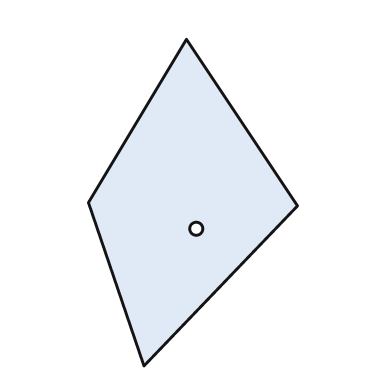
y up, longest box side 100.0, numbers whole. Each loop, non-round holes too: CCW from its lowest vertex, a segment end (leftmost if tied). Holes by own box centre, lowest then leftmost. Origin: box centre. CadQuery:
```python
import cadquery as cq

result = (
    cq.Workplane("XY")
    .moveTo(-15.0, -50.0)
    .lineTo(32.0, -1.0)
    .lineTo(-2.0, 50.0)
    .lineTo(-32.0, 0.0)
    .close()
    .moveTo(1.0, -8.0)
    .circle(2.0)
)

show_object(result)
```